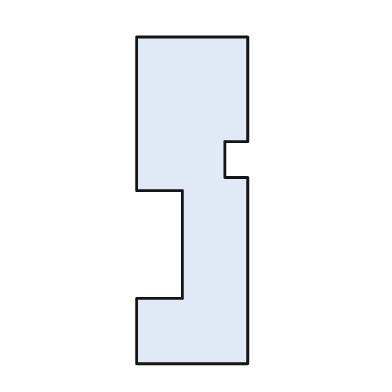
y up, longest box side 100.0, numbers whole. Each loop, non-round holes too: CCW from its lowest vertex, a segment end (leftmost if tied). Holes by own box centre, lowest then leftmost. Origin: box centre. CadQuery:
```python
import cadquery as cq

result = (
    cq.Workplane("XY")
    .moveTo(-17.0, -50.0)
    .lineTo(17.0, -50.0)
    .lineTo(17.0, 7.0)
    .lineTo(10.0, 7.0)
    .lineTo(10.0, 18.0)
    .lineTo(17.0, 18.0)
    .lineTo(17.0, 50.0)
    .lineTo(-17.0, 50.0)
    .lineTo(-17.0, 3.0)
    .lineTo(-3.0, 3.0)
    .lineTo(-3.0, -30.0)
    .lineTo(-17.0, -30.0)
    .close()
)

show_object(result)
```